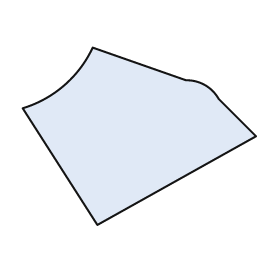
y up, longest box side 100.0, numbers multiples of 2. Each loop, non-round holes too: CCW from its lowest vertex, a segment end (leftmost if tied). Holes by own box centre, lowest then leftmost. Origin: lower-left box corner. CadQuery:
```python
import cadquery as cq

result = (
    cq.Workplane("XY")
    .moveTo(32.0, 0.0)
    .lineTo(100.0, 38.0)
    .lineTo(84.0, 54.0)
    .threePointArc((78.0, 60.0), (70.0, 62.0))
    .lineTo(30.0, 76.0)
    .threePointArc((18.0, 60.0), (0.0, 50.0))
    .close()
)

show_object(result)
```